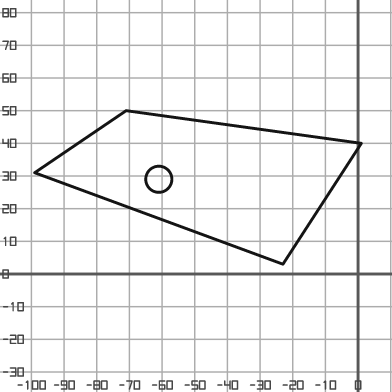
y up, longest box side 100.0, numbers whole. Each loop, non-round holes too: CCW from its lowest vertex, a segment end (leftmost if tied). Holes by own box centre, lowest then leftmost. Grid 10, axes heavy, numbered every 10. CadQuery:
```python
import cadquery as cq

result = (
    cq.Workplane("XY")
    .moveTo(-23.0, 3.0)
    .lineTo(1.0, 40.0)
    .lineTo(-71.0, 50.0)
    .lineTo(-99.0, 31.0)
    .close()
    .moveTo(-61.0, 29.0)
    .circle(4.0)
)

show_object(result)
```